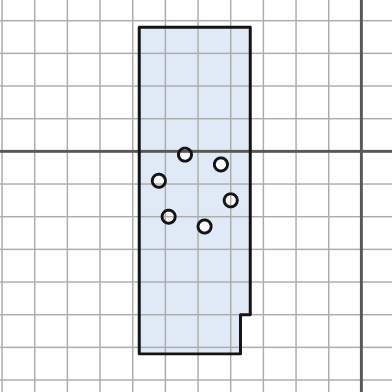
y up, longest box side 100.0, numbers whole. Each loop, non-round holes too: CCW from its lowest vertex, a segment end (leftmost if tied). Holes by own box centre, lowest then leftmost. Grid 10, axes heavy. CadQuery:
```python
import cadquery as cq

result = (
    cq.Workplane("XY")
    .moveTo(-68.0, -62.0)
    .lineTo(-37.0, -62.0)
    .lineTo(-37.0, -50.0)
    .lineTo(-34.0, -50.0)
    .lineTo(-34.0, 38.0)
    .lineTo(-68.0, 38.0)
    .close()
    .moveTo(-48.0, -23.0)
    .circle(2.0)
    .moveTo(-59.0, -20.0)
    .circle(2.0)
    .moveTo(-40.0, -15.0)
    .circle(2.0)
    .moveTo(-62.0, -9.0)
    .circle(2.0)
    .moveTo(-43.0, -4.0)
    .circle(2.0)
    .moveTo(-54.0, -1.0)
    .circle(2.0)
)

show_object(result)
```